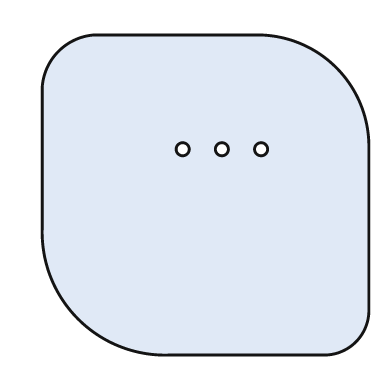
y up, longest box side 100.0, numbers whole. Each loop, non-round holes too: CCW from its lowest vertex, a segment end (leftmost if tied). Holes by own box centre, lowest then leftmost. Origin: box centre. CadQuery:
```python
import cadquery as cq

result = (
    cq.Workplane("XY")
    .moveTo(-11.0, -49.0)
    .lineTo(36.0, -49.0)
    .threePointArc((46.0, -45.0), (50.0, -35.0))
    .lineTo(50.0, 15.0)
    .threePointArc((40.0, 39.0), (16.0, 49.0))
    .lineTo(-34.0, 49.0)
    .threePointArc((-45.0, 44.0), (-50.0, 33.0))
    .lineTo(-50.0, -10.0)
    .threePointArc((-39.0, -38.0), (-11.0, -49.0))
    .close()
    .moveTo(-7.0, 14.0)
    .circle(2.0)
    .moveTo(5.0, 14.0)
    .circle(2.0)
    .moveTo(17.0, 14.0)
    .circle(2.0)
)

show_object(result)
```